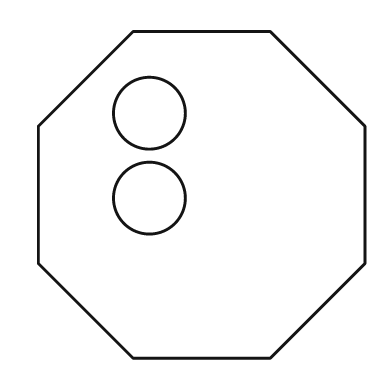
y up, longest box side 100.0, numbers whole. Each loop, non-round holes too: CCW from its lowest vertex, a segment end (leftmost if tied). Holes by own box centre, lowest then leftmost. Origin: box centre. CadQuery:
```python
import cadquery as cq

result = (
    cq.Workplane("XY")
    .moveTo(-21.0, -50.0)
    .lineTo(21.0, -50.0)
    .lineTo(50.0, -21.0)
    .lineTo(50.0, 21.0)
    .lineTo(21.0, 50.0)
    .lineTo(-21.0, 50.0)
    .lineTo(-50.0, 21.0)
    .lineTo(-50.0, -21.0)
    .close()
    .moveTo(-16.0, -1.0)
    .circle(11.0)
    .moveTo(-16.0, 25.0)
    .circle(11.0)
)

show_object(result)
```